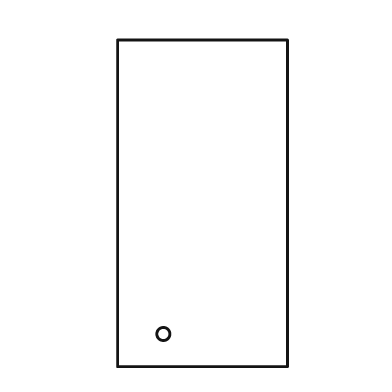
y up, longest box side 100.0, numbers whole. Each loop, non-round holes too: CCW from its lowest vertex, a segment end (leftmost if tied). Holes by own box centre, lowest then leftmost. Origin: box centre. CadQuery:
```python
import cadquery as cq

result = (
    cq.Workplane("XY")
    .moveTo(-26.0, -50.0)
    .lineTo(26.0, -50.0)
    .lineTo(26.0, 50.0)
    .lineTo(-26.0, 50.0)
    .close()
    .moveTo(-12.0, -40.0)
    .circle(2.0)
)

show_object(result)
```